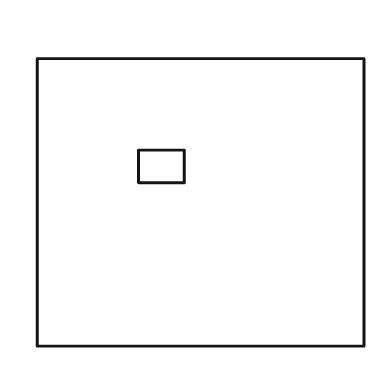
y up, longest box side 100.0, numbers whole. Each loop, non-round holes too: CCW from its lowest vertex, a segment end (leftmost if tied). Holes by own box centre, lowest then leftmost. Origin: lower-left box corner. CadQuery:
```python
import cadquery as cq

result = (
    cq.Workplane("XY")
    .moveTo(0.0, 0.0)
    .lineTo(100.0, 0.0)
    .lineTo(100.0, 88.0)
    .lineTo(0.0, 88.0)
    .close()
    .moveTo(31.0, 50.0)
    .lineTo(45.0, 50.0)
    .lineTo(45.0, 60.0)
    .lineTo(31.0, 60.0)
    .close()
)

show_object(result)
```